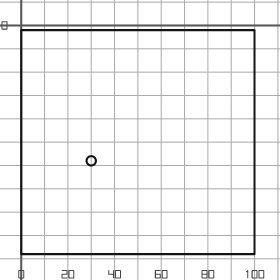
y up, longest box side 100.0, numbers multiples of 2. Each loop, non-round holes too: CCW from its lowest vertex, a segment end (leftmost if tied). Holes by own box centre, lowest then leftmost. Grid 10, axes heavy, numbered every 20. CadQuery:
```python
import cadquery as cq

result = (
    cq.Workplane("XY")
    .moveTo(0.0, -98.0)
    .lineTo(100.0, -98.0)
    .lineTo(100.0, -2.0)
    .lineTo(0.0, -2.0)
    .close()
    .moveTo(30.0, -58.0)
    .circle(2.0)
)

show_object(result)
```